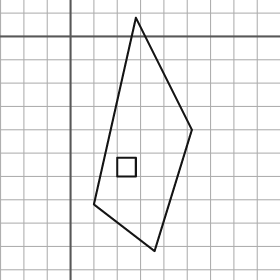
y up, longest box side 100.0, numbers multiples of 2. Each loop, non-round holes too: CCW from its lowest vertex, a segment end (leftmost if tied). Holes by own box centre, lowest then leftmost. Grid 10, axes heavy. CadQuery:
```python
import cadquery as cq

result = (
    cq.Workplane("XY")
    .moveTo(36.0, -92.0)
    .lineTo(52.0, -40.0)
    .lineTo(28.0, 8.0)
    .lineTo(10.0, -72.0)
    .close()
    .moveTo(20.0, -60.0)
    .lineTo(28.0, -60.0)
    .lineTo(28.0, -52.0)
    .lineTo(20.0, -52.0)
    .close()
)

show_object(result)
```